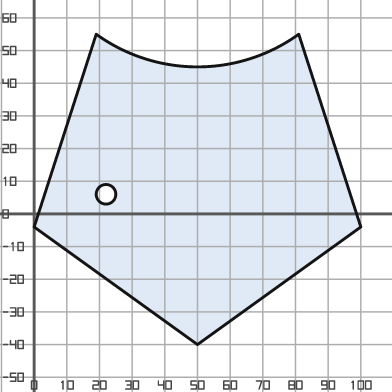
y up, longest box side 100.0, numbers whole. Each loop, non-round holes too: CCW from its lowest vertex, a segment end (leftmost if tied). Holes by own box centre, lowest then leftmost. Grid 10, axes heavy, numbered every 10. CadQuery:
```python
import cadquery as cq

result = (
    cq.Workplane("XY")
    .moveTo(50.0, -40.0)
    .lineTo(100.0, -4.0)
    .lineTo(81.0, 55.0)
    .threePointArc((50.0, 45.0), (19.0, 55.0))
    .lineTo(0.0, -4.0)
    .close()
    .moveTo(22.0, 6.0)
    .circle(3.0)
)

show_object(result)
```